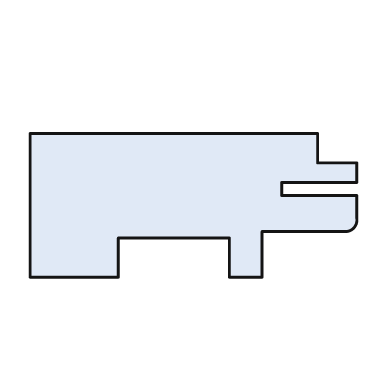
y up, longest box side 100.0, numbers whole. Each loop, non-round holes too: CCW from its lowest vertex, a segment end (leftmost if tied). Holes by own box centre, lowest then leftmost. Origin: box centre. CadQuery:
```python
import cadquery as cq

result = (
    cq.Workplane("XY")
    .moveTo(-50.0, -22.0)
    .lineTo(-23.0, -22.0)
    .lineTo(-23.0, -10.0)
    .lineTo(11.0, -10.0)
    .lineTo(11.0, -22.0)
    .lineTo(21.0, -22.0)
    .lineTo(21.0, -8.0)
    .lineTo(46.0, -8.0)
    .threePointArc((49.0, -7.0), (50.0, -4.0))
    .lineTo(50.0, 3.0)
    .lineTo(27.0, 3.0)
    .lineTo(27.0, 7.0)
    .lineTo(50.0, 7.0)
    .lineTo(50.0, 13.0)
    .lineTo(38.0, 13.0)
    .lineTo(38.0, 22.0)
    .lineTo(-50.0, 22.0)
    .close()
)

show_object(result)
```